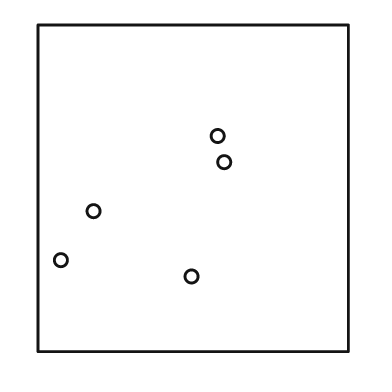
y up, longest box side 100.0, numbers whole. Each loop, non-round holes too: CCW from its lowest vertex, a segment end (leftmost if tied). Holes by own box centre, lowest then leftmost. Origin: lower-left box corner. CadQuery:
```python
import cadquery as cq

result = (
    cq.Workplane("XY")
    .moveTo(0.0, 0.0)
    .lineTo(95.0, 0.0)
    .lineTo(95.0, 100.0)
    .lineTo(0.0, 100.0)
    .close()
    .moveTo(47.0, 23.0)
    .circle(2.0)
    .moveTo(7.0, 28.0)
    .circle(2.0)
    .moveTo(17.0, 43.0)
    .circle(2.0)
    .moveTo(57.0, 58.0)
    .circle(2.0)
    .moveTo(55.0, 66.0)
    .circle(2.0)
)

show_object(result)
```